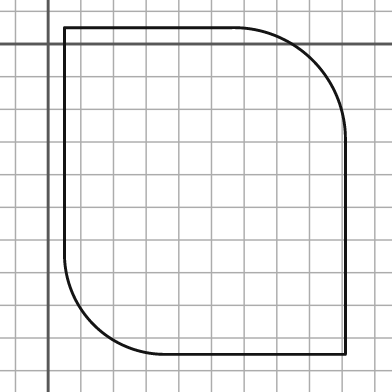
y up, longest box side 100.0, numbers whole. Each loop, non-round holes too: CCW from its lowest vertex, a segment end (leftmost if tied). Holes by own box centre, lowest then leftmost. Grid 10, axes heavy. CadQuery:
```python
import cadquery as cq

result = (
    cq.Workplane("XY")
    .moveTo(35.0, -95.0)
    .lineTo(91.0, -95.0)
    .lineTo(91.0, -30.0)
    .threePointArc((81.0, -5.0), (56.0, 5.0))
    .lineTo(5.0, 5.0)
    .lineTo(5.0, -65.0)
    .threePointArc((14.0, -86.0), (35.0, -95.0))
    .close()
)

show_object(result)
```